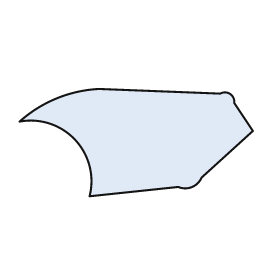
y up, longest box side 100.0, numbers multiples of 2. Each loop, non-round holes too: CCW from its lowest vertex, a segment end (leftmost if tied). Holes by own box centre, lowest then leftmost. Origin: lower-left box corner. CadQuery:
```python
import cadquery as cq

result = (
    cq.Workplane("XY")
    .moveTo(30.0, 0.0)
    .lineTo(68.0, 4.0)
    .threePointArc((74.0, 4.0), (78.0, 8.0))
    .lineTo(100.0, 28.0)
    .lineTo(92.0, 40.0)
    .threePointArc((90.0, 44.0), (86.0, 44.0))
    .lineTo(34.0, 46.0)
    .threePointArc((16.0, 42.0), (0.0, 32.0))
    .threePointArc((24.0, 24.0), (30.0, 0.0))
    .close()
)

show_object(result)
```